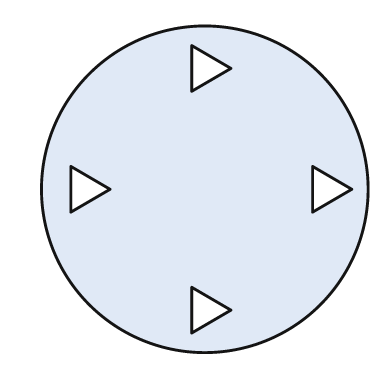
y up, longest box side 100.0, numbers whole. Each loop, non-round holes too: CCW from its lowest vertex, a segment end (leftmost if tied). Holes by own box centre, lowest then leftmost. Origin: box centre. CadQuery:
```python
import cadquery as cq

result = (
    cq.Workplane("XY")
    .moveTo(0.0, 0.0)
    .circle(50.0)
    .moveTo(-4.0, -44.0)
    .lineTo(8.0, -37.0)
    .lineTo(-4.0, -30.0)
    .close()
    .moveTo(-41.0, -7.0)
    .lineTo(-29.0, 0.0)
    .lineTo(-41.0, 7.0)
    .close()
    .moveTo(33.0, -7.0)
    .lineTo(45.0, 0.0)
    .lineTo(33.0, 7.0)
    .close()
    .moveTo(-4.0, 30.0)
    .lineTo(8.0, 37.0)
    .lineTo(-4.0, 44.0)
    .close()
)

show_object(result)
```